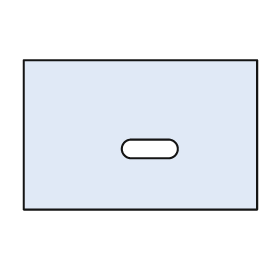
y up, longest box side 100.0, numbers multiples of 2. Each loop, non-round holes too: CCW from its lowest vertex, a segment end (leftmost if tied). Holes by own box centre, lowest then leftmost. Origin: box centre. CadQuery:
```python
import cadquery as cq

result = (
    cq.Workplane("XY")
    .moveTo(-50.0, -32.0)
    .lineTo(50.0, -32.0)
    .lineTo(50.0, 32.0)
    .lineTo(-50.0, 32.0)
    .close()
    .moveTo(-4.0, -10.0)
    .lineTo(12.0, -10.0)
    .threePointArc((16.0, -6.0), (12.0, -2.0))
    .lineTo(-4.0, -2.0)
    .threePointArc((-8.0, -6.0), (-4.0, -10.0))
    .close()
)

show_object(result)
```